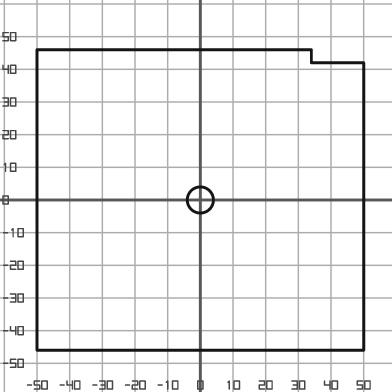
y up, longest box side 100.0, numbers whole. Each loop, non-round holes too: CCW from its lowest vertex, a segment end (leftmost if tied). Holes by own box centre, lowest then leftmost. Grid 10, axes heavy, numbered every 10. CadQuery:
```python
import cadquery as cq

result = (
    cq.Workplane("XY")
    .moveTo(-50.0, -46.0)
    .lineTo(50.0, -46.0)
    .lineTo(50.0, 42.0)
    .lineTo(34.0, 42.0)
    .lineTo(34.0, 46.0)
    .lineTo(-50.0, 46.0)
    .close()
    .moveTo(0.0, 0.0)
    .circle(4.0)
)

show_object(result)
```